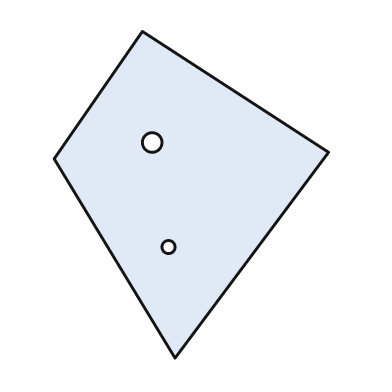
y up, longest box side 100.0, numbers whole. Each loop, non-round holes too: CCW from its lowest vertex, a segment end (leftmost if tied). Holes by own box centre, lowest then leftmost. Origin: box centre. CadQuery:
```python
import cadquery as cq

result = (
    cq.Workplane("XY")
    .moveTo(-5.0, -50.0)
    .lineTo(42.0, 13.0)
    .lineTo(-15.0, 50.0)
    .lineTo(-42.0, 11.0)
    .close()
    .moveTo(-7.0, -16.0)
    .circle(2.0)
    .moveTo(-12.0, 16.0)
    .circle(3.0)
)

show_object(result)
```